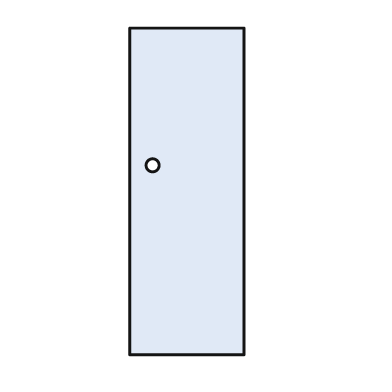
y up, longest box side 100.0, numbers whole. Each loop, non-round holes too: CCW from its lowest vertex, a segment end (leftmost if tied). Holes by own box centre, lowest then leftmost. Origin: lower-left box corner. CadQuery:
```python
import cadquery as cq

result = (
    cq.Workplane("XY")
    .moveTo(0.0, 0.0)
    .lineTo(35.0, 0.0)
    .lineTo(35.0, 100.0)
    .lineTo(0.0, 100.0)
    .close()
    .moveTo(7.0, 58.0)
    .circle(2.0)
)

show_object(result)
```